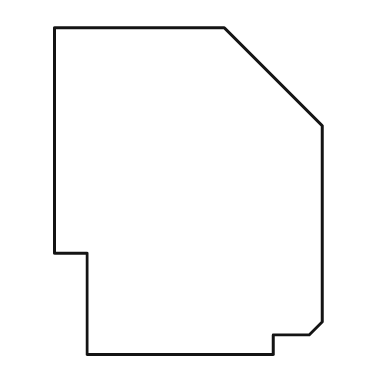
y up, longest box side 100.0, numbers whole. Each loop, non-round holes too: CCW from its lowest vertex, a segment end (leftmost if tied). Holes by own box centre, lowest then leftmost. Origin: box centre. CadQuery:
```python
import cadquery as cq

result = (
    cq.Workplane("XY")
    .moveTo(-31.0, -50.0)
    .lineTo(26.0, -50.0)
    .lineTo(26.0, -44.0)
    .lineTo(37.0, -44.0)
    .lineTo(41.0, -40.0)
    .lineTo(41.0, 20.0)
    .lineTo(11.0, 50.0)
    .lineTo(-41.0, 50.0)
    .lineTo(-41.0, -19.0)
    .lineTo(-31.0, -19.0)
    .close()
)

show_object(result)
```